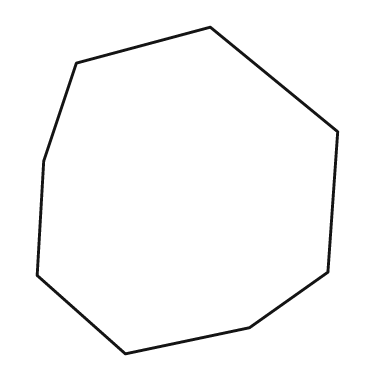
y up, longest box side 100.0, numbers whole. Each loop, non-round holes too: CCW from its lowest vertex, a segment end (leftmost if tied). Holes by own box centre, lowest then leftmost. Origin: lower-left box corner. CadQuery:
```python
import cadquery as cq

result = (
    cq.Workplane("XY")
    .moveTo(27.0, 0.0)
    .lineTo(65.0, 8.0)
    .lineTo(89.0, 25.0)
    .lineTo(92.0, 68.0)
    .lineTo(53.0, 100.0)
    .lineTo(12.0, 89.0)
    .lineTo(2.0, 59.0)
    .lineTo(0.0, 24.0)
    .close()
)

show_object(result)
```